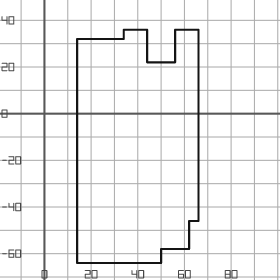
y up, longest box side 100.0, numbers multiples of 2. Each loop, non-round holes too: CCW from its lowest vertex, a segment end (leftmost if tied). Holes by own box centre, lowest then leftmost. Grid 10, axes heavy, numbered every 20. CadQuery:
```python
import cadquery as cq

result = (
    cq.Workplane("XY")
    .moveTo(14.0, -64.0)
    .lineTo(50.0, -64.0)
    .lineTo(50.0, -58.0)
    .lineTo(62.0, -58.0)
    .lineTo(62.0, -46.0)
    .lineTo(66.0, -46.0)
    .lineTo(66.0, 36.0)
    .lineTo(56.0, 36.0)
    .lineTo(56.0, 22.0)
    .lineTo(44.0, 22.0)
    .lineTo(44.0, 36.0)
    .lineTo(34.0, 36.0)
    .lineTo(34.0, 32.0)
    .lineTo(14.0, 32.0)
    .close()
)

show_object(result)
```